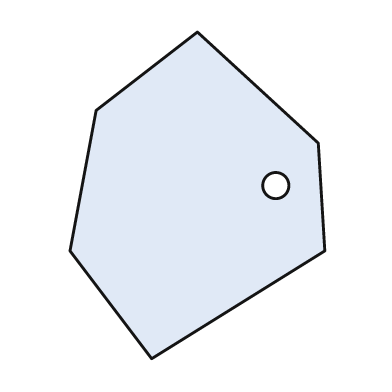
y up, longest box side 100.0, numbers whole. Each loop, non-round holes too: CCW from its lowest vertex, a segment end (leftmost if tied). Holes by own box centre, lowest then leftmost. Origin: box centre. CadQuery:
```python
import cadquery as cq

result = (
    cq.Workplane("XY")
    .moveTo(-14.0, -50.0)
    .lineTo(39.0, -17.0)
    .lineTo(37.0, 16.0)
    .lineTo(0.0, 50.0)
    .lineTo(-31.0, 26.0)
    .lineTo(-39.0, -17.0)
    .close()
    .moveTo(24.0, 3.0)
    .circle(4.0)
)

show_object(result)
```